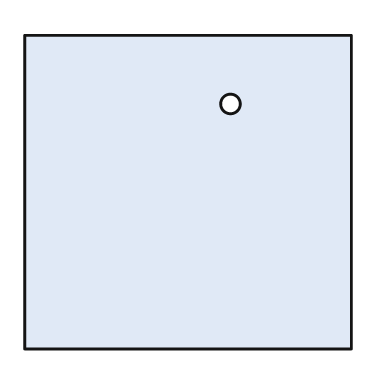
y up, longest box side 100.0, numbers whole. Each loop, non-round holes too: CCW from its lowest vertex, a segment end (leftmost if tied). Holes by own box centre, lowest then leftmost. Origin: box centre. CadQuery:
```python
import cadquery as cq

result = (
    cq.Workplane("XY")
    .moveTo(-50.0, -48.0)
    .lineTo(50.0, -48.0)
    .lineTo(50.0, 48.0)
    .lineTo(-50.0, 48.0)
    .close()
    .moveTo(13.0, 27.0)
    .circle(3.0)
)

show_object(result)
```